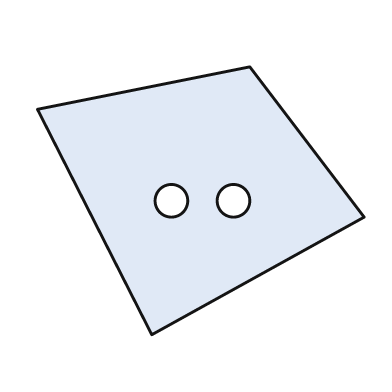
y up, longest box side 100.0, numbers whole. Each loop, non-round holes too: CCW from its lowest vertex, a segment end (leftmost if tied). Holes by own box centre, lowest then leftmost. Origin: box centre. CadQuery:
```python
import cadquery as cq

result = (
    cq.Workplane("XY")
    .moveTo(-15.0, -41.0)
    .lineTo(50.0, -5.0)
    .lineTo(15.0, 41.0)
    .lineTo(-50.0, 28.0)
    .close()
    .moveTo(-9.0, 0.0)
    .circle(5.0)
    .moveTo(10.0, 0.0)
    .circle(5.0)
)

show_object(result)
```